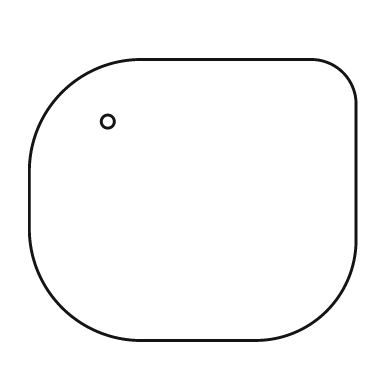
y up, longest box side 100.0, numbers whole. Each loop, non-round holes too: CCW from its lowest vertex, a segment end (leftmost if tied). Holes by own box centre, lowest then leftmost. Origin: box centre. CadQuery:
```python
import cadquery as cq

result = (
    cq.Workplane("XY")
    .moveTo(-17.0, -43.0)
    .lineTo(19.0, -43.0)
    .threePointArc((41.0, -34.0), (50.0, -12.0))
    .lineTo(50.0, 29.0)
    .threePointArc((46.0, 39.0), (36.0, 43.0))
    .lineTo(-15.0, 43.0)
    .threePointArc((-40.0, 33.0), (-50.0, 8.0))
    .lineTo(-50.0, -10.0)
    .threePointArc((-40.0, -33.0), (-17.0, -43.0))
    .close()
    .moveTo(-26.0, 24.0)
    .circle(2.0)
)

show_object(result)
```